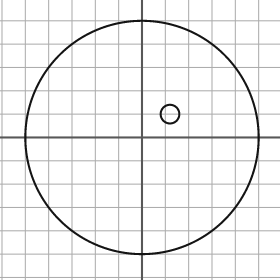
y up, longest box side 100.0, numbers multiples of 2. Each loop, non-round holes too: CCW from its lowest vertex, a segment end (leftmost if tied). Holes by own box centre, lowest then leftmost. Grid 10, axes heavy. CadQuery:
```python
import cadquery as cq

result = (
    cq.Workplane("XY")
    .moveTo(0.0, 0.0)
    .circle(50.0)
    .moveTo(12.0, 10.0)
    .circle(4.0)
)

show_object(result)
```